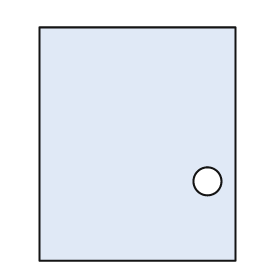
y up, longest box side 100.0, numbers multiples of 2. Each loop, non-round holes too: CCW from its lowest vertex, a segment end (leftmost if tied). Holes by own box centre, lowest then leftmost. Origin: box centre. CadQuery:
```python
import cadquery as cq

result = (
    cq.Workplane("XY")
    .moveTo(-42.0, -50.0)
    .lineTo(42.0, -50.0)
    .lineTo(42.0, 50.0)
    .lineTo(-42.0, 50.0)
    .close()
    .moveTo(30.0, -16.0)
    .circle(6.0)
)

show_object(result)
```